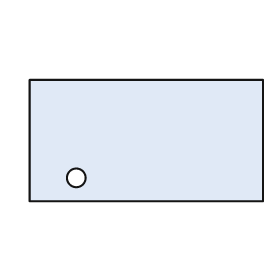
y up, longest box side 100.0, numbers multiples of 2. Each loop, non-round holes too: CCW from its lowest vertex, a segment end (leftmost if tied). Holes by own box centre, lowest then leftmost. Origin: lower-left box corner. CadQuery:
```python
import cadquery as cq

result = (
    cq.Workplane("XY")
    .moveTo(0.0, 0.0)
    .lineTo(100.0, 0.0)
    .lineTo(100.0, 52.0)
    .lineTo(0.0, 52.0)
    .close()
    .moveTo(20.0, 10.0)
    .circle(4.0)
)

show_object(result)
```